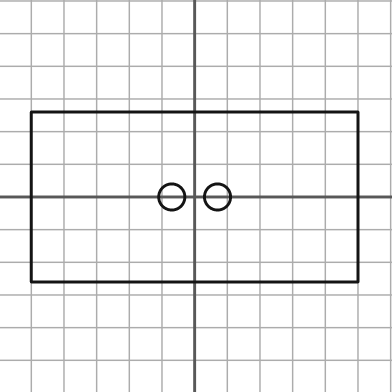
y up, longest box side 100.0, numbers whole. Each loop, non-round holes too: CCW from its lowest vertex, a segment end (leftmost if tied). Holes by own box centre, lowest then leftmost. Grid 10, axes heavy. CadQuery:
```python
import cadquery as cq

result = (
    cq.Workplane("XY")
    .moveTo(-50.0, -26.0)
    .lineTo(50.0, -26.0)
    .lineTo(50.0, 26.0)
    .lineTo(-50.0, 26.0)
    .close()
    .moveTo(-7.0, 0.0)
    .circle(4.0)
    .moveTo(7.0, 0.0)
    .circle(4.0)
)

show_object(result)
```